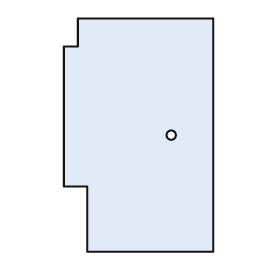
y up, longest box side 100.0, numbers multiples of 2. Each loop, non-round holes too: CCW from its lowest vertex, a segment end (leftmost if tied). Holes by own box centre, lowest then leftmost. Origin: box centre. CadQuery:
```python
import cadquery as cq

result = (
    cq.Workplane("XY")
    .moveTo(-22.0, -50.0)
    .lineTo(32.0, -50.0)
    .lineTo(32.0, 50.0)
    .lineTo(-26.0, 50.0)
    .lineTo(-26.0, 38.0)
    .lineTo(-32.0, 38.0)
    .lineTo(-32.0, -22.0)
    .lineTo(-22.0, -22.0)
    .close()
    .moveTo(14.0, 0.0)
    .circle(2.0)
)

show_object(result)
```